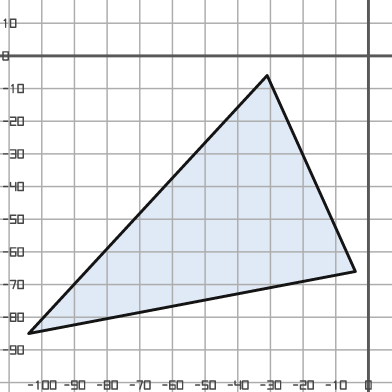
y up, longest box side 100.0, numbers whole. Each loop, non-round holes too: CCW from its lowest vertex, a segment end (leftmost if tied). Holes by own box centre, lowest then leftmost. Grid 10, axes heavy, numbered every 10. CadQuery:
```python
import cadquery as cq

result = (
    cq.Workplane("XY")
    .moveTo(-104.0, -85.0)
    .lineTo(-4.0, -66.0)
    .lineTo(-31.0, -6.0)
    .close()
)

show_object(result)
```